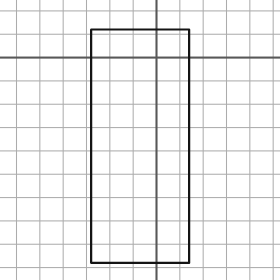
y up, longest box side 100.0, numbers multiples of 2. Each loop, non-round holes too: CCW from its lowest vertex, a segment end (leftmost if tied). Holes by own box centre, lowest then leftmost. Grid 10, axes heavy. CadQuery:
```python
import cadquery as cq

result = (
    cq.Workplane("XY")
    .moveTo(-28.0, -88.0)
    .lineTo(14.0, -88.0)
    .lineTo(14.0, 12.0)
    .lineTo(-28.0, 12.0)
    .close()
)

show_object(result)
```